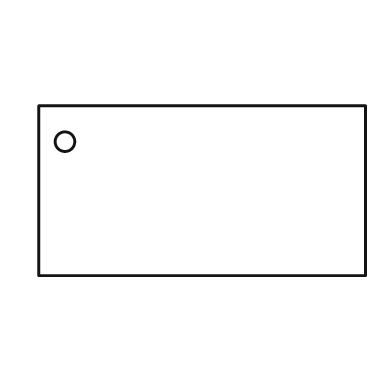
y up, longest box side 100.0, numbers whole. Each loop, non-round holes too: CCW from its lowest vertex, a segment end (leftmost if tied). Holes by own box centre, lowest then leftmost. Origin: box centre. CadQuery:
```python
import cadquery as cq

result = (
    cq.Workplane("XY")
    .moveTo(-50.0, -26.0)
    .lineTo(50.0, -26.0)
    .lineTo(50.0, 26.0)
    .lineTo(-50.0, 26.0)
    .close()
    .moveTo(-42.0, 15.0)
    .circle(3.0)
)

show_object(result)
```